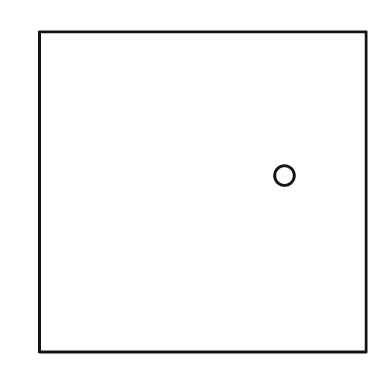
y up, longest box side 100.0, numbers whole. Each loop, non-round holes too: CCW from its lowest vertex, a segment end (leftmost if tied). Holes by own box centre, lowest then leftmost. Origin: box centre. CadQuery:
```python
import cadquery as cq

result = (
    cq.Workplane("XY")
    .moveTo(-50.0, -49.0)
    .lineTo(50.0, -49.0)
    .lineTo(50.0, 49.0)
    .lineTo(-50.0, 49.0)
    .close()
    .moveTo(25.0, 5.0)
    .circle(3.0)
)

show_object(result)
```